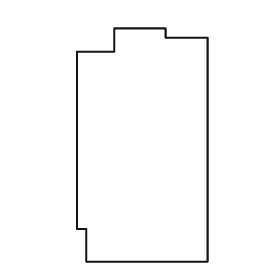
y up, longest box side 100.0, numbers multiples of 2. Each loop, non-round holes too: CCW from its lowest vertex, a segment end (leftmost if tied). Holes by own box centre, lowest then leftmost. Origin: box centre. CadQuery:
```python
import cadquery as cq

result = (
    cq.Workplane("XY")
    .moveTo(-24.0, -50.0)
    .lineTo(28.0, -50.0)
    .lineTo(28.0, 46.0)
    .lineTo(10.0, 46.0)
    .lineTo(10.0, 50.0)
    .lineTo(-12.0, 50.0)
    .lineTo(-12.0, 40.0)
    .lineTo(-28.0, 40.0)
    .lineTo(-28.0, -36.0)
    .lineTo(-24.0, -36.0)
    .close()
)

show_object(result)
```